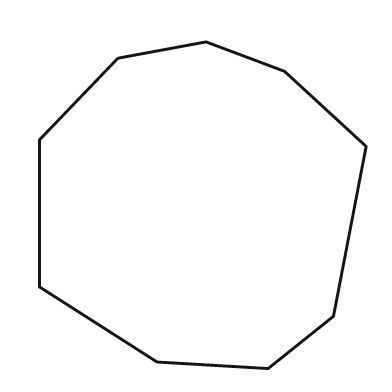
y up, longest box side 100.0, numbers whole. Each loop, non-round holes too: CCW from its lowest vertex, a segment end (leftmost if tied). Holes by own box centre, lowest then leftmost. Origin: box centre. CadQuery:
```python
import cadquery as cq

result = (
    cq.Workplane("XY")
    .moveTo(20.0, -50.0)
    .lineTo(40.0, -34.0)
    .lineTo(50.0, 18.0)
    .lineTo(25.0, 41.0)
    .lineTo(1.0, 50.0)
    .lineTo(-26.0, 45.0)
    .lineTo(-50.0, 20.0)
    .lineTo(-50.0, -25.0)
    .lineTo(-14.0, -48.0)
    .close()
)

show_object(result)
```